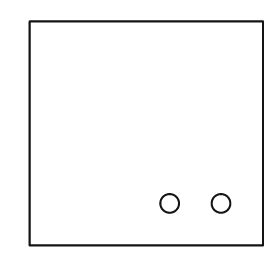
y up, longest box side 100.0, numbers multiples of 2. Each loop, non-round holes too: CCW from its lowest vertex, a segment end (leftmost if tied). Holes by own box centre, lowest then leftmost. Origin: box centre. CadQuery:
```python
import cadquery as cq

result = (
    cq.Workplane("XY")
    .moveTo(-50.0, -48.0)
    .lineTo(50.0, -48.0)
    .lineTo(50.0, 48.0)
    .lineTo(-50.0, 48.0)
    .close()
    .moveTo(10.0, -30.0)
    .circle(4.0)
    .moveTo(32.0, -30.0)
    .circle(4.0)
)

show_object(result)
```